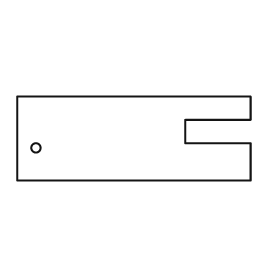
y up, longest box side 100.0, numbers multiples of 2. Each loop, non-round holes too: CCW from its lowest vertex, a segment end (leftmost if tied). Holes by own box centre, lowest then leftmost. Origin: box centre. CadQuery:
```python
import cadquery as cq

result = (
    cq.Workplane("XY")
    .moveTo(-50.0, -18.0)
    .lineTo(50.0, -18.0)
    .lineTo(50.0, -2.0)
    .lineTo(22.0, -2.0)
    .lineTo(22.0, 8.0)
    .lineTo(50.0, 8.0)
    .lineTo(50.0, 18.0)
    .lineTo(-50.0, 18.0)
    .close()
    .moveTo(-42.0, -4.0)
    .circle(2.0)
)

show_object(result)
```